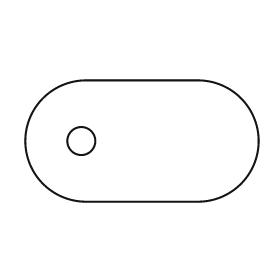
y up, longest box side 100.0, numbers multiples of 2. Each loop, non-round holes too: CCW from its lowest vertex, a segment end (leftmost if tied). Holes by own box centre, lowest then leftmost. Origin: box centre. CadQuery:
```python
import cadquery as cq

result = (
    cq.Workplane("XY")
    .moveTo(-24.0, -26.0)
    .lineTo(24.0, -26.0)
    .threePointArc((50.0, 0.0), (24.0, 26.0))
    .lineTo(-24.0, 26.0)
    .threePointArc((-50.0, 0.0), (-24.0, -26.0))
    .close()
    .moveTo(-26.0, 0.0)
    .circle(6.0)
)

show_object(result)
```